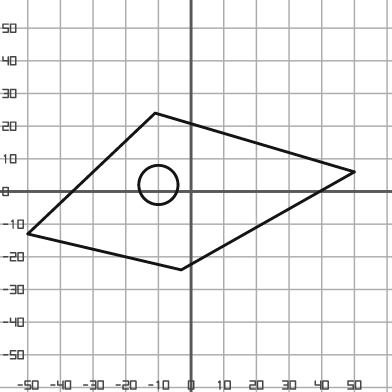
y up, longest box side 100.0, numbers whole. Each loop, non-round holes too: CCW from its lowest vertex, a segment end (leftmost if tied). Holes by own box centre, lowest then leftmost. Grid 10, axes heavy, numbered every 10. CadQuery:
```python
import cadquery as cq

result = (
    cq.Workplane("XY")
    .moveTo(-3.0, -24.0)
    .lineTo(50.0, 6.0)
    .lineTo(-11.0, 24.0)
    .lineTo(-50.0, -13.0)
    .close()
    .moveTo(-10.0, 2.0)
    .circle(6.0)
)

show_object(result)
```